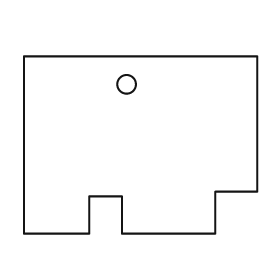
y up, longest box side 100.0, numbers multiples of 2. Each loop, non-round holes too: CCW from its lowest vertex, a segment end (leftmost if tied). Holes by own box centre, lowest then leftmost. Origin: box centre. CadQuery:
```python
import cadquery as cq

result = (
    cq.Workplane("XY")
    .moveTo(-50.0, -38.0)
    .lineTo(-22.0, -38.0)
    .lineTo(-22.0, -22.0)
    .lineTo(-8.0, -22.0)
    .lineTo(-8.0, -38.0)
    .lineTo(32.0, -38.0)
    .lineTo(32.0, -20.0)
    .lineTo(50.0, -20.0)
    .lineTo(50.0, 38.0)
    .lineTo(-50.0, 38.0)
    .close()
    .moveTo(-6.0, 26.0)
    .circle(4.0)
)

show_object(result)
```